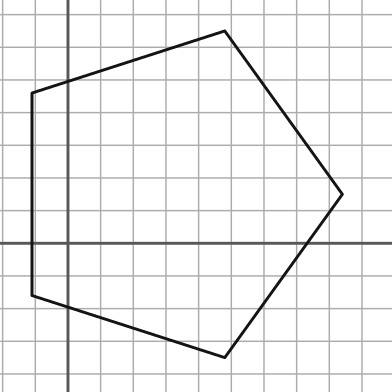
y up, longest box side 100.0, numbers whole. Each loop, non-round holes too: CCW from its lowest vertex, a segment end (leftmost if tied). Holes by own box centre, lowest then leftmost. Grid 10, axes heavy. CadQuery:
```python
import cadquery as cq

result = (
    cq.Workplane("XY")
    .moveTo(48.0, -35.0)
    .lineTo(84.0, 15.0)
    .lineTo(48.0, 65.0)
    .lineTo(-11.0, 46.0)
    .lineTo(-11.0, -16.0)
    .close()
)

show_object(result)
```